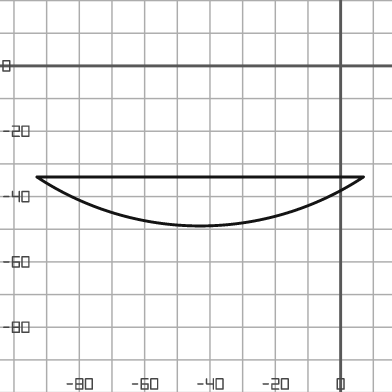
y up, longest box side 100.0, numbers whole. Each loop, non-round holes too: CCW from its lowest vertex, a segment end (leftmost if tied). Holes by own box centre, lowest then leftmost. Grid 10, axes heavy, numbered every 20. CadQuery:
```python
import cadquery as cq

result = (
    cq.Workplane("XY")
    .moveTo(-93.0, -34.0)
    .threePointArc((-43.0, -49.0), (7.0, -34.0))
    .close()
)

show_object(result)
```